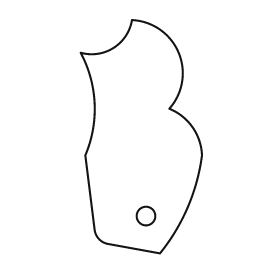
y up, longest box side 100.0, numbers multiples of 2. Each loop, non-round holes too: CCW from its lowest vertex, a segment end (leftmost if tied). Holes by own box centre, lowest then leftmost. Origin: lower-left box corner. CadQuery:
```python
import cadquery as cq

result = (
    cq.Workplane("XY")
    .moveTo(34.0, 0.0)
    .threePointArc((46.0, 20.0), (52.0, 42.0))
    .threePointArc((48.0, 54.0), (38.0, 62.0))
    .threePointArc((42.0, 86.0), (22.0, 100.0))
    .threePointArc((14.0, 88.0), (0.0, 86.0))
    .threePointArc((6.0, 64.0), (2.0, 42.0))
    .lineTo(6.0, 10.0)
    .threePointArc((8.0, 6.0), (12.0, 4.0))
    .close()
    .moveTo(28.0, 16.0)
    .circle(4.0)
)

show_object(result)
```